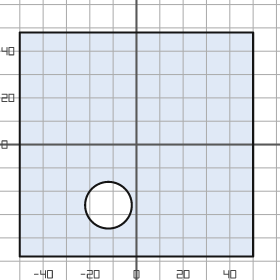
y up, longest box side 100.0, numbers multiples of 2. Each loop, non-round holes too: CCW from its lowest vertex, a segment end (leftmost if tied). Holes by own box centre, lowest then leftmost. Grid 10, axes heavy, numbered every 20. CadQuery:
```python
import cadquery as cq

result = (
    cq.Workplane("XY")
    .moveTo(-50.0, -48.0)
    .lineTo(50.0, -48.0)
    .lineTo(50.0, 48.0)
    .lineTo(-50.0, 48.0)
    .close()
    .moveTo(-12.0, -26.0)
    .circle(10.0)
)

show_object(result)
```